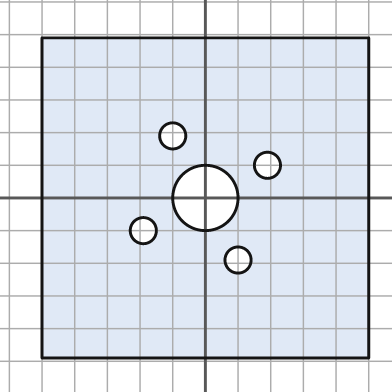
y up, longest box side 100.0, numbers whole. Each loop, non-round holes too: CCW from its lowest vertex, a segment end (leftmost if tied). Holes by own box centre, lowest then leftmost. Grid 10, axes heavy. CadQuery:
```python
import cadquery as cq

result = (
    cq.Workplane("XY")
    .moveTo(-50.0, -49.0)
    .lineTo(50.0, -49.0)
    .lineTo(50.0, 49.0)
    .lineTo(-50.0, 49.0)
    .close()
    .moveTo(10.0, -19.0)
    .circle(4.0)
    .moveTo(-19.0, -10.0)
    .circle(4.0)
    .moveTo(0.0, 0.0)
    .circle(10.0)
    .moveTo(19.0, 10.0)
    .circle(4.0)
    .moveTo(-10.0, 19.0)
    .circle(4.0)
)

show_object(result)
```